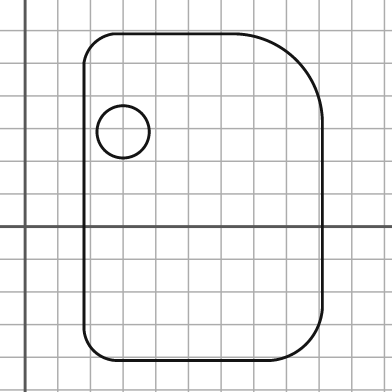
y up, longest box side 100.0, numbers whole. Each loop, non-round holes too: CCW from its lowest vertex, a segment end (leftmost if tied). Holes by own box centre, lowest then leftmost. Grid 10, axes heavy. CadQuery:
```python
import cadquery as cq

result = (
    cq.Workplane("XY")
    .moveTo(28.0, -41.0)
    .lineTo(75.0, -41.0)
    .threePointArc((86.0, -36.0), (91.0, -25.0))
    .lineTo(91.0, 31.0)
    .threePointArc((83.0, 51.0), (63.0, 59.0))
    .lineTo(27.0, 59.0)
    .threePointArc((21.0, 56.0), (18.0, 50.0))
    .lineTo(18.0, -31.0)
    .threePointArc((21.0, -38.0), (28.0, -41.0))
    .close()
    .moveTo(30.0, 29.0)
    .circle(8.0)
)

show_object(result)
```